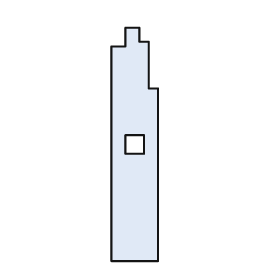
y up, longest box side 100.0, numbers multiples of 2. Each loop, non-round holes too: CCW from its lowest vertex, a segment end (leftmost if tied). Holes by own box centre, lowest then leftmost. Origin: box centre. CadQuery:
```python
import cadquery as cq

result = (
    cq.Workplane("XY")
    .moveTo(-10.0, -50.0)
    .lineTo(10.0, -50.0)
    .lineTo(10.0, 24.0)
    .lineTo(6.0, 24.0)
    .lineTo(6.0, 44.0)
    .lineTo(2.0, 44.0)
    .lineTo(2.0, 50.0)
    .lineTo(-4.0, 50.0)
    .lineTo(-4.0, 42.0)
    .lineTo(-10.0, 42.0)
    .close()
    .moveTo(-4.0, -4.0)
    .lineTo(4.0, -4.0)
    .lineTo(4.0, 4.0)
    .lineTo(-4.0, 4.0)
    .close()
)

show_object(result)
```